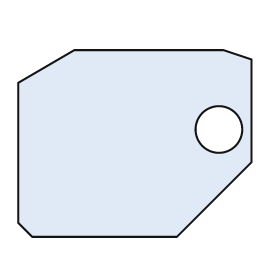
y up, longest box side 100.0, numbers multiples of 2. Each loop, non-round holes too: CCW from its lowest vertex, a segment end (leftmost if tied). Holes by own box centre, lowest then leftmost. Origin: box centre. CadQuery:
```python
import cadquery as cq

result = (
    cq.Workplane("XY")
    .moveTo(-44.0, -40.0)
    .lineTo(18.0, -40.0)
    .lineTo(50.0, -8.0)
    .lineTo(50.0, 36.0)
    .lineTo(38.0, 40.0)
    .lineTo(-26.0, 40.0)
    .lineTo(-50.0, 26.0)
    .lineTo(-50.0, -34.0)
    .close()
    .moveTo(36.0, 6.0)
    .circle(10.0)
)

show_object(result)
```